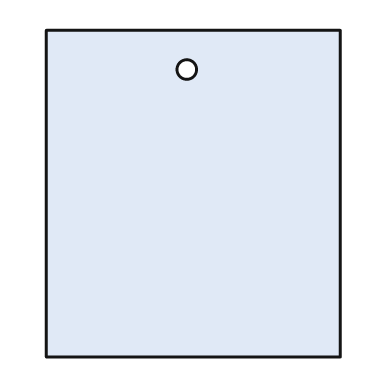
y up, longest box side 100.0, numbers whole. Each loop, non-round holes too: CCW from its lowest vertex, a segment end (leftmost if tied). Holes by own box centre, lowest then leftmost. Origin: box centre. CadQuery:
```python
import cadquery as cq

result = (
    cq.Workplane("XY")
    .moveTo(-45.0, -50.0)
    .lineTo(45.0, -50.0)
    .lineTo(45.0, 50.0)
    .lineTo(-45.0, 50.0)
    .close()
    .moveTo(-2.0, 38.0)
    .circle(3.0)
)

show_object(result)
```